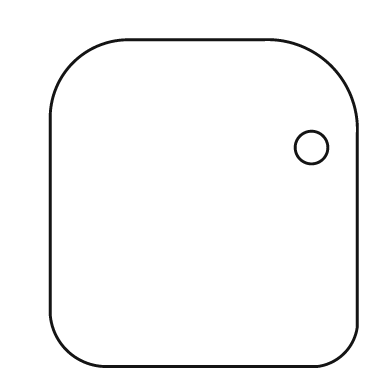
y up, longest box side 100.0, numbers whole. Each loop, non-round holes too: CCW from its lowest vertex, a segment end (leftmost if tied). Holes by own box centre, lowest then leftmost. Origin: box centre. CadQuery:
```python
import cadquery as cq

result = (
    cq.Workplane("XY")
    .moveTo(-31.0, -50.0)
    .lineTo(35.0, -50.0)
    .threePointArc((43.0, -46.0), (47.0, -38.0))
    .lineTo(47.0, 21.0)
    .threePointArc((39.0, 42.0), (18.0, 50.0))
    .lineTo(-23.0, 50.0)
    .threePointArc((-40.0, 43.0), (-47.0, 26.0))
    .lineTo(-47.0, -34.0)
    .threePointArc((-42.0, -45.0), (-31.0, -50.0))
    .close()
    .moveTo(33.0, 17.0)
    .circle(5.0)
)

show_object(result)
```